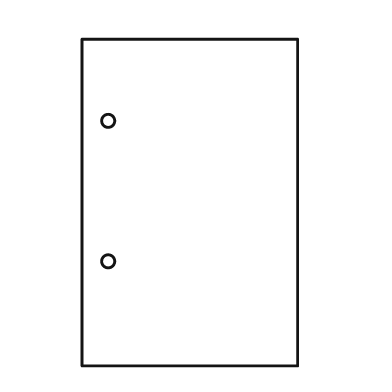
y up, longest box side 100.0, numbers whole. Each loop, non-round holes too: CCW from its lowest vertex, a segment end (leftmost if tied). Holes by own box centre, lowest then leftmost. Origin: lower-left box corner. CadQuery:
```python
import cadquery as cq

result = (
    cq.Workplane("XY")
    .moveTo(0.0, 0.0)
    .lineTo(66.0, 0.0)
    .lineTo(66.0, 100.0)
    .lineTo(0.0, 100.0)
    .close()
    .moveTo(8.0, 32.0)
    .circle(2.0)
    .moveTo(8.0, 75.0)
    .circle(2.0)
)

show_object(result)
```